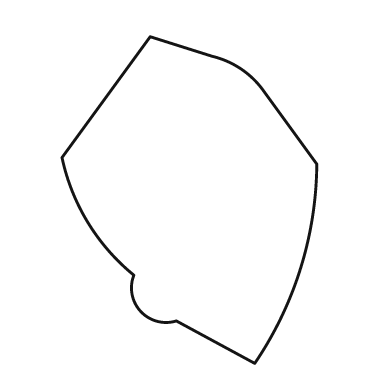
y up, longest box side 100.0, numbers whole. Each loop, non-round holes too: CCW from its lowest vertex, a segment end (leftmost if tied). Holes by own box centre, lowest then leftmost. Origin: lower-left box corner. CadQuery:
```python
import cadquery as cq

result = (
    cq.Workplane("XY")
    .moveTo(59.0, 0.0)
    .threePointArc((73.0, 29.0), (78.0, 61.0))
    .lineTo(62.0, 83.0)
    .threePointArc((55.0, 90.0), (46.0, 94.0))
    .lineTo(27.0, 100.0)
    .lineTo(0.0, 63.0)
    .threePointArc((8.0, 43.0), (22.0, 27.0))
    .threePointArc((24.0, 16.0), (35.0, 13.0))
    .close()
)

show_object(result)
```